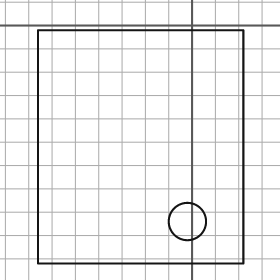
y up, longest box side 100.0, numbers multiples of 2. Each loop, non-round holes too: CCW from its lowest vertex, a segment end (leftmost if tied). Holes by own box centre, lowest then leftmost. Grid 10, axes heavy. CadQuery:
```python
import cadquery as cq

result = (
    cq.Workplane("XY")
    .moveTo(-66.0, -102.0)
    .lineTo(22.0, -102.0)
    .lineTo(22.0, -2.0)
    .lineTo(-66.0, -2.0)
    .close()
    .moveTo(-2.0, -84.0)
    .circle(8.0)
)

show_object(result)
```